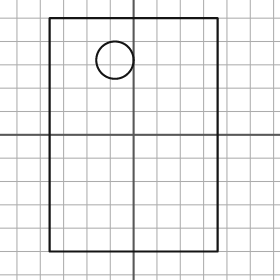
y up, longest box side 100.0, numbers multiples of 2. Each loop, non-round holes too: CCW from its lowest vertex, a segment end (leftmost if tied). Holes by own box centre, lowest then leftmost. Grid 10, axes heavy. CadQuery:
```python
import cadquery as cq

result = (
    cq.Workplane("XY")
    .moveTo(-36.0, -50.0)
    .lineTo(36.0, -50.0)
    .lineTo(36.0, 50.0)
    .lineTo(-36.0, 50.0)
    .close()
    .moveTo(-8.0, 32.0)
    .circle(8.0)
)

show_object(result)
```